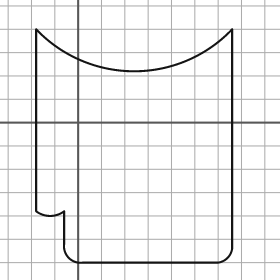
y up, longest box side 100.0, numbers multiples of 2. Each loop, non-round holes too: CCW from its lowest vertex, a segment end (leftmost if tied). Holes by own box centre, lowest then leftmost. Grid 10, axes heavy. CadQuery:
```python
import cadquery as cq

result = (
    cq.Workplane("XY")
    .moveTo(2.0, -60.0)
    .lineTo(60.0, -60.0)
    .threePointArc((64.0, -58.0), (66.0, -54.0))
    .lineTo(66.0, 40.0)
    .threePointArc((24.0, 22.0), (-18.0, 40.0))
    .lineTo(-18.0, -38.0)
    .threePointArc((-12.0, -40.0), (-6.0, -38.0))
    .lineTo(-6.0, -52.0)
    .threePointArc((-4.0, -58.0), (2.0, -60.0))
    .close()
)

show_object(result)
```